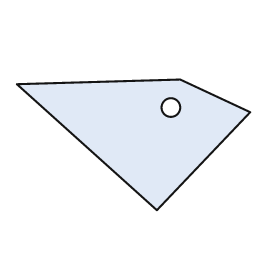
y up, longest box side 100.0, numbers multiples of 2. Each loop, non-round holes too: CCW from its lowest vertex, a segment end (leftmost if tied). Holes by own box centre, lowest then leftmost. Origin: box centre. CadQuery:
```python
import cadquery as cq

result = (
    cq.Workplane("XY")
    .moveTo(10.0, -28.0)
    .lineTo(50.0, 14.0)
    .lineTo(20.0, 28.0)
    .lineTo(-50.0, 26.0)
    .close()
    .moveTo(16.0, 16.0)
    .circle(4.0)
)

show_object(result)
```